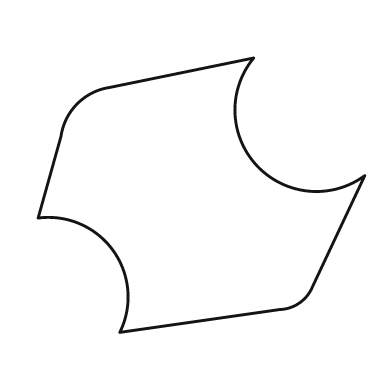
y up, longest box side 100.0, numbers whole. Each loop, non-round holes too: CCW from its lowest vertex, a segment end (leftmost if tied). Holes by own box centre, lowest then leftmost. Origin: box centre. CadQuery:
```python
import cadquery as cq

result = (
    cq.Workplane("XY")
    .moveTo(-25.0, -42.0)
    .lineTo(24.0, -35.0)
    .threePointArc((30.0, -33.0), (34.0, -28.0))
    .lineTo(50.0, 6.0)
    .threePointArc((17.0, 9.0), (16.0, 42.0))
    .lineTo(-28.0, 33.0)
    .threePointArc((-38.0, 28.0), (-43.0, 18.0))
    .lineTo(-50.0, -7.0)
    .threePointArc((-27.0, -17.0), (-25.0, -42.0))
    .close()
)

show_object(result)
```